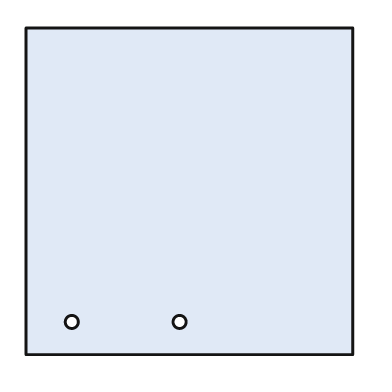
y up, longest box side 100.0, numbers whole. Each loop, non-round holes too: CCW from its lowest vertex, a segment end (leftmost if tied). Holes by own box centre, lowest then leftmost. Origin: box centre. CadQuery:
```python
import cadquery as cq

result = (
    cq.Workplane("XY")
    .moveTo(-50.0, -50.0)
    .lineTo(50.0, -50.0)
    .lineTo(50.0, 50.0)
    .lineTo(-50.0, 50.0)
    .close()
    .moveTo(-36.0, -40.0)
    .circle(2.0)
    .moveTo(-3.0, -40.0)
    .circle(2.0)
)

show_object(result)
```